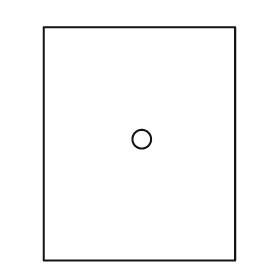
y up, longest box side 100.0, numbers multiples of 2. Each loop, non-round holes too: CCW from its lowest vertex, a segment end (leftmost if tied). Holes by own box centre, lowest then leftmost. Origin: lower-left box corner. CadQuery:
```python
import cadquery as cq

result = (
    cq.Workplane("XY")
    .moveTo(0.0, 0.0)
    .lineTo(82.0, 0.0)
    .lineTo(82.0, 100.0)
    .lineTo(0.0, 100.0)
    .close()
    .moveTo(42.0, 52.0)
    .circle(4.0)
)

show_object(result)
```